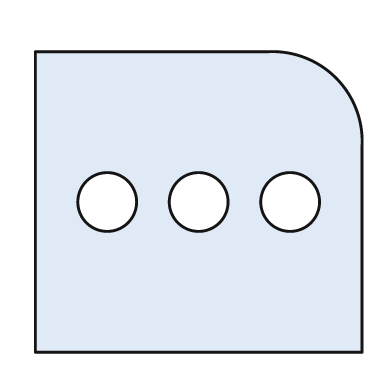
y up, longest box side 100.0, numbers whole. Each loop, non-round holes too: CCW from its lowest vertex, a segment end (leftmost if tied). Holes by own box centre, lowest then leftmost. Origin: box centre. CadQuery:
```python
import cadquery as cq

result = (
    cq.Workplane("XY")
    .moveTo(-50.0, -46.0)
    .lineTo(50.0, -46.0)
    .lineTo(50.0, 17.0)
    .threePointArc((42.0, 38.0), (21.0, 46.0))
    .lineTo(-50.0, 46.0)
    .close()
    .moveTo(-28.0, 0.0)
    .circle(9.0)
    .moveTo(0.0, 0.0)
    .circle(9.0)
    .moveTo(28.0, 0.0)
    .circle(9.0)
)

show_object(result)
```